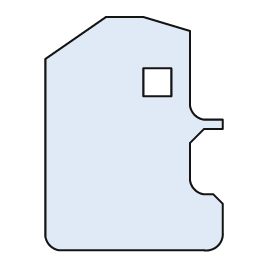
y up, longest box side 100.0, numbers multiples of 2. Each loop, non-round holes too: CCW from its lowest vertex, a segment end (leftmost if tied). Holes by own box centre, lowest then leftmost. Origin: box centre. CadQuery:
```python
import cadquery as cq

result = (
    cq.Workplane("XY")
    .moveTo(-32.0, -50.0)
    .lineTo(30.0, -50.0)
    .threePointArc((36.0, -48.0), (38.0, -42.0))
    .lineTo(38.0, -30.0)
    .lineTo(34.0, -26.0)
    .lineTo(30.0, -26.0)
    .threePointArc((26.0, -24.0), (24.0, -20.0))
    .lineTo(24.0, -4.0)
    .lineTo(30.0, 2.0)
    .lineTo(38.0, 2.0)
    .lineTo(38.0, 6.0)
    .lineTo(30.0, 6.0)
    .threePointArc((26.0, 8.0), (24.0, 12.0))
    .lineTo(24.0, 44.0)
    .lineTo(4.0, 50.0)
    .lineTo(-12.0, 50.0)
    .lineTo(-38.0, 32.0)
    .lineTo(-38.0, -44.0)
    .threePointArc((-36.0, -48.0), (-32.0, -50.0))
    .close()
    .moveTo(4.0, 16.0)
    .lineTo(16.0, 16.0)
    .lineTo(16.0, 28.0)
    .lineTo(4.0, 28.0)
    .close()
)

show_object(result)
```